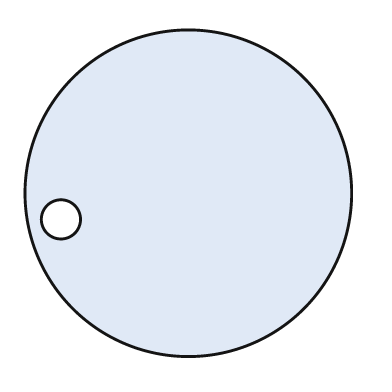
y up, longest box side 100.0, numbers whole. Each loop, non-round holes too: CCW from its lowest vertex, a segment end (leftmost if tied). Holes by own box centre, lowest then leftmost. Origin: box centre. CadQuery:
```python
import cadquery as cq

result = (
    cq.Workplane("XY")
    .moveTo(0.0, 0.0)
    .circle(50.0)
    .moveTo(-39.0, -8.0)
    .circle(6.0)
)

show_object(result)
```